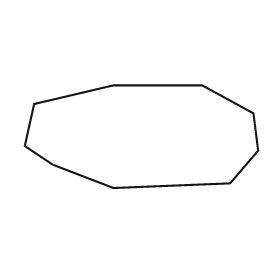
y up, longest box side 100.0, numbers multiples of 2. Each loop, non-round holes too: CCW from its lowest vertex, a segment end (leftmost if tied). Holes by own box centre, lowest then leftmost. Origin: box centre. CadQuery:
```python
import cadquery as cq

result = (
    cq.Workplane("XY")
    .moveTo(-12.0, -22.0)
    .lineTo(38.0, -20.0)
    .lineTo(50.0, -6.0)
    .lineTo(48.0, 10.0)
    .lineTo(26.0, 22.0)
    .lineTo(-12.0, 22.0)
    .lineTo(-46.0, 14.0)
    .lineTo(-50.0, -4.0)
    .lineTo(-38.0, -12.0)
    .close()
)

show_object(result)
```